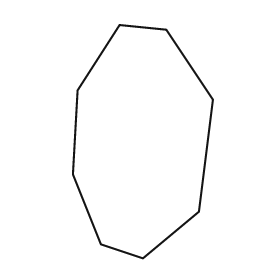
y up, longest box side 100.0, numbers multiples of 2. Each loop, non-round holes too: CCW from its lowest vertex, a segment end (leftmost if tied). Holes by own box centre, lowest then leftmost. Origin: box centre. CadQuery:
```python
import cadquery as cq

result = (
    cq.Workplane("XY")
    .moveTo(0.0, -50.0)
    .lineTo(24.0, -30.0)
    .lineTo(30.0, 18.0)
    .lineTo(10.0, 48.0)
    .lineTo(-10.0, 50.0)
    .lineTo(-28.0, 22.0)
    .lineTo(-30.0, -14.0)
    .lineTo(-18.0, -44.0)
    .close()
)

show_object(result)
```